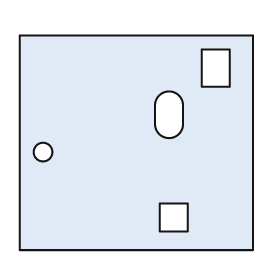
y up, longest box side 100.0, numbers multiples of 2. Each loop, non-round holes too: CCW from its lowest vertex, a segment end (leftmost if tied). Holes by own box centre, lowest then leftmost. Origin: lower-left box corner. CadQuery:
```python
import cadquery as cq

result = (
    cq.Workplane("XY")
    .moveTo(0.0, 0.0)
    .lineTo(100.0, 0.0)
    .lineTo(100.0, 92.0)
    .lineTo(0.0, 92.0)
    .close()
    .moveTo(60.0, 8.0)
    .lineTo(72.0, 8.0)
    .lineTo(72.0, 20.0)
    .lineTo(60.0, 20.0)
    .close()
    .moveTo(10.0, 42.0)
    .circle(4.0)
    .moveTo(58.0, 54.0)
    .threePointArc((64.0, 48.0), (70.0, 54.0))
    .lineTo(70.0, 62.0)
    .threePointArc((64.0, 68.0), (58.0, 62.0))
    .close()
    .moveTo(78.0, 70.0)
    .lineTo(90.0, 70.0)
    .lineTo(90.0, 86.0)
    .lineTo(78.0, 86.0)
    .close()
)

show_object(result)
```